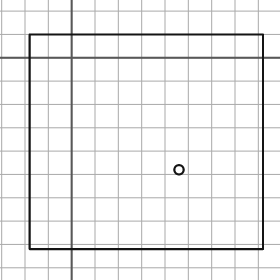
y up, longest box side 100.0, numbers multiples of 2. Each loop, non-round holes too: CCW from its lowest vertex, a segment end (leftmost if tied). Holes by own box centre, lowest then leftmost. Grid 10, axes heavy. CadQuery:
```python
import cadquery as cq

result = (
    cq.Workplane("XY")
    .moveTo(-18.0, -82.0)
    .lineTo(82.0, -82.0)
    .lineTo(82.0, 10.0)
    .lineTo(-18.0, 10.0)
    .close()
    .moveTo(46.0, -48.0)
    .circle(2.0)
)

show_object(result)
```